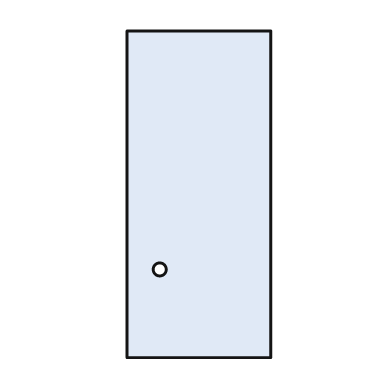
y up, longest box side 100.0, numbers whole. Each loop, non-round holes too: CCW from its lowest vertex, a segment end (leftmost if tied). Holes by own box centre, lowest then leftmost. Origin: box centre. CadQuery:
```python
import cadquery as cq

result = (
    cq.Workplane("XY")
    .moveTo(-22.0, -50.0)
    .lineTo(22.0, -50.0)
    .lineTo(22.0, 50.0)
    .lineTo(-22.0, 50.0)
    .close()
    .moveTo(-12.0, -23.0)
    .circle(2.0)
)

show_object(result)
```